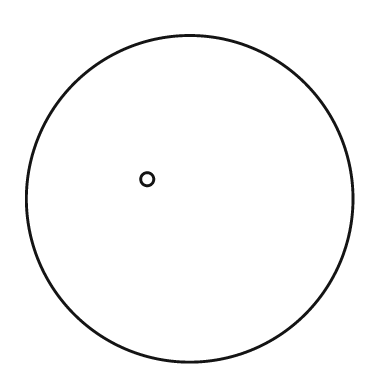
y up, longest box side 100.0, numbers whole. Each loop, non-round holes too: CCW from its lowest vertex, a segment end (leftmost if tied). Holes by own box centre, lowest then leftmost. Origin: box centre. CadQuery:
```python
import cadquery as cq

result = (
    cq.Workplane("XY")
    .moveTo(0.0, 0.0)
    .circle(50.0)
    .moveTo(-13.0, 6.0)
    .circle(2.0)
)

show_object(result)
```